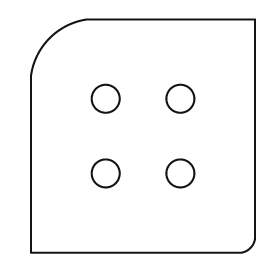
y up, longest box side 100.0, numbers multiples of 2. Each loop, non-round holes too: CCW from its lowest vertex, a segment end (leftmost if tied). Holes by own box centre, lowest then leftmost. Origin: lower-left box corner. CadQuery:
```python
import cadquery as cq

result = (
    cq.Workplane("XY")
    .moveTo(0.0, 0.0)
    .lineTo(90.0, 0.0)
    .threePointArc((94.0, 2.0), (96.0, 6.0))
    .lineTo(96.0, 100.0)
    .lineTo(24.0, 100.0)
    .threePointArc((8.0, 92.0), (0.0, 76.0))
    .close()
    .moveTo(32.0, 34.0)
    .circle(6.0)
    .moveTo(64.0, 34.0)
    .circle(6.0)
    .moveTo(32.0, 66.0)
    .circle(6.0)
    .moveTo(64.0, 66.0)
    .circle(6.0)
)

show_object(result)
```